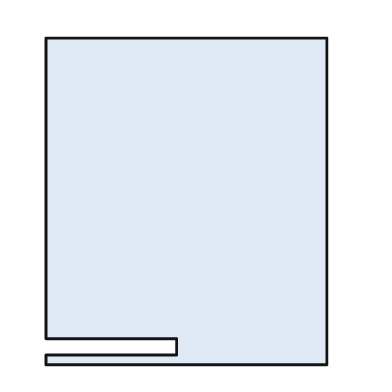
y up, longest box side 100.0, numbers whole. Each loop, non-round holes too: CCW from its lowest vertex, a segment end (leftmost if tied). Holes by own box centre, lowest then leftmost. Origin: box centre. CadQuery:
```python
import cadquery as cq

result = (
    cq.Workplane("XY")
    .moveTo(-43.0, -50.0)
    .lineTo(43.0, -50.0)
    .lineTo(43.0, 50.0)
    .lineTo(-43.0, 50.0)
    .lineTo(-43.0, -42.0)
    .lineTo(-3.0, -42.0)
    .lineTo(-3.0, -47.0)
    .lineTo(-43.0, -47.0)
    .close()
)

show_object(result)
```